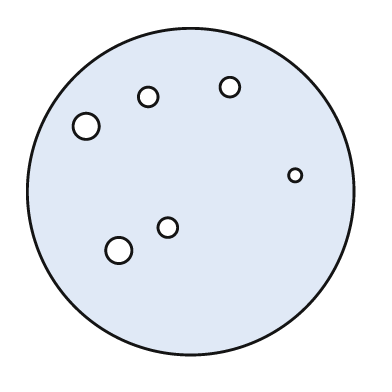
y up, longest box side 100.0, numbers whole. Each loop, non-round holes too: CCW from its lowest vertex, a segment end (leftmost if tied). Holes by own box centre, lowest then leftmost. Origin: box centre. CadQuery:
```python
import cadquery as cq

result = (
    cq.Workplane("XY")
    .moveTo(0.0, 0.0)
    .circle(50.0)
    .moveTo(-22.0, -18.0)
    .circle(4.0)
    .moveTo(-7.0, -11.0)
    .circle(3.0)
    .moveTo(32.0, 5.0)
    .circle(2.0)
    .moveTo(-32.0, 20.0)
    .circle(4.0)
    .moveTo(-13.0, 29.0)
    .circle(3.0)
    .moveTo(12.0, 32.0)
    .circle(3.0)
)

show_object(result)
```